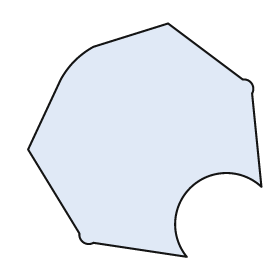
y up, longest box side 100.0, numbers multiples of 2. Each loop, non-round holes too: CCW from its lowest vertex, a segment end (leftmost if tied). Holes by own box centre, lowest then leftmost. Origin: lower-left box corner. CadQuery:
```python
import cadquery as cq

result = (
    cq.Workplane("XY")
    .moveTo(68.0, 0.0)
    .threePointArc((70.0, 30.0), (100.0, 30.0))
    .lineTo(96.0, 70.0)
    .threePointArc((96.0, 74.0), (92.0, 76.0))
    .lineTo(60.0, 100.0)
    .lineTo(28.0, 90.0)
    .threePointArc((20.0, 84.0), (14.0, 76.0))
    .lineTo(0.0, 46.0)
    .lineTo(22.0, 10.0)
    .threePointArc((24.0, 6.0), (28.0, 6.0))
    .close()
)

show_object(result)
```